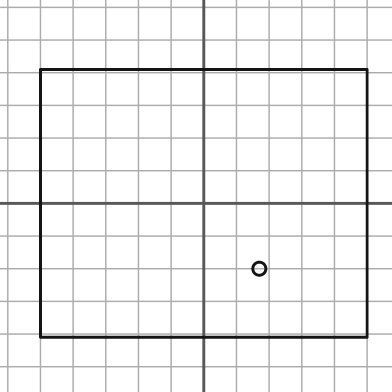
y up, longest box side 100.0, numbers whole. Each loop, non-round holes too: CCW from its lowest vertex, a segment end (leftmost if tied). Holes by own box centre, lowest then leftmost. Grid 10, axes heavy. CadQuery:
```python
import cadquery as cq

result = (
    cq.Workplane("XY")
    .moveTo(-50.0, -41.0)
    .lineTo(50.0, -41.0)
    .lineTo(50.0, 41.0)
    .lineTo(-50.0, 41.0)
    .close()
    .moveTo(17.0, -20.0)
    .circle(2.0)
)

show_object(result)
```